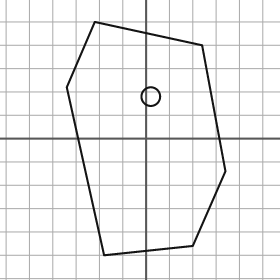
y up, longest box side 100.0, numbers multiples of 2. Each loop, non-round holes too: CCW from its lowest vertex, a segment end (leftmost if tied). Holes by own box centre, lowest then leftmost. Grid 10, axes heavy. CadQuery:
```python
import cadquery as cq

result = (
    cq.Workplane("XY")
    .moveTo(-18.0, -50.0)
    .lineTo(20.0, -46.0)
    .lineTo(34.0, -14.0)
    .lineTo(24.0, 40.0)
    .lineTo(-22.0, 50.0)
    .lineTo(-34.0, 22.0)
    .close()
    .moveTo(2.0, 18.0)
    .circle(4.0)
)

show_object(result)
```